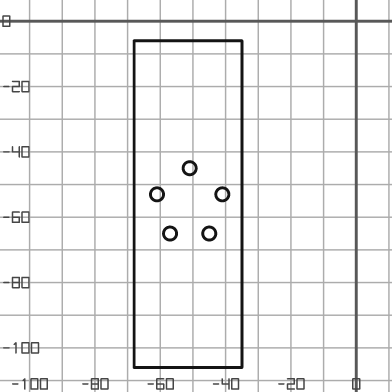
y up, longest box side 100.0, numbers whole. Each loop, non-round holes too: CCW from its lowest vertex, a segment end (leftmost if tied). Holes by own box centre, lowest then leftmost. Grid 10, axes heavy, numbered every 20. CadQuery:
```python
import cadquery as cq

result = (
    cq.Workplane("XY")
    .moveTo(-68.0, -106.0)
    .lineTo(-35.0, -106.0)
    .lineTo(-35.0, -6.0)
    .lineTo(-68.0, -6.0)
    .close()
    .moveTo(-57.0, -65.0)
    .circle(2.0)
    .moveTo(-45.0, -65.0)
    .circle(2.0)
    .moveTo(-61.0, -53.0)
    .circle(2.0)
    .moveTo(-41.0, -53.0)
    .circle(2.0)
    .moveTo(-51.0, -45.0)
    .circle(2.0)
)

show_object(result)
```